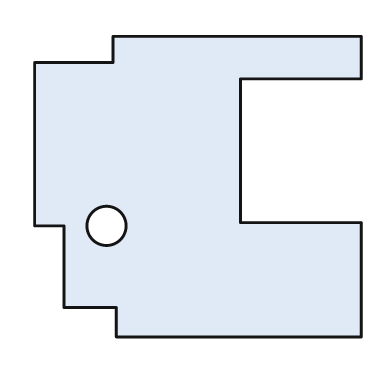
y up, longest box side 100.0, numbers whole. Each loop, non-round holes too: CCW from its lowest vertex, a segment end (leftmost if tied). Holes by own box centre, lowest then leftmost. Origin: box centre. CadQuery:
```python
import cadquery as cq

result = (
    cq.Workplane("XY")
    .moveTo(-25.0, -46.0)
    .lineTo(50.0, -46.0)
    .lineTo(50.0, -11.0)
    .lineTo(13.0, -11.0)
    .lineTo(13.0, 33.0)
    .lineTo(50.0, 33.0)
    .lineTo(50.0, 46.0)
    .lineTo(-26.0, 46.0)
    .lineTo(-26.0, 38.0)
    .lineTo(-50.0, 38.0)
    .lineTo(-50.0, -12.0)
    .lineTo(-41.0, -12.0)
    .lineTo(-41.0, -37.0)
    .lineTo(-25.0, -37.0)
    .close()
    .moveTo(-28.0, -12.0)
    .circle(6.0)
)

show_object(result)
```